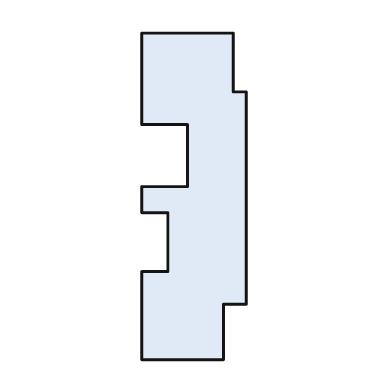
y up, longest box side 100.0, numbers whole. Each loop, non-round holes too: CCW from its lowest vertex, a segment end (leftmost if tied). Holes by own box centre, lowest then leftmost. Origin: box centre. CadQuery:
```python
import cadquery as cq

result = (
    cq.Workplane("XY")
    .moveTo(-16.0, -50.0)
    .lineTo(9.0, -50.0)
    .lineTo(9.0, -33.0)
    .lineTo(16.0, -33.0)
    .lineTo(16.0, 32.0)
    .lineTo(12.0, 32.0)
    .lineTo(12.0, 50.0)
    .lineTo(-16.0, 50.0)
    .lineTo(-16.0, 22.0)
    .lineTo(-2.0, 22.0)
    .lineTo(-2.0, 3.0)
    .lineTo(-16.0, 3.0)
    .lineTo(-16.0, -5.0)
    .lineTo(-8.0, -5.0)
    .lineTo(-8.0, -23.0)
    .lineTo(-16.0, -23.0)
    .close()
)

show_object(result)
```